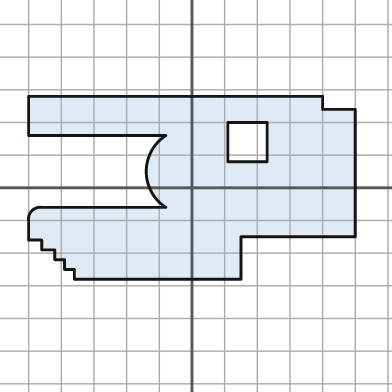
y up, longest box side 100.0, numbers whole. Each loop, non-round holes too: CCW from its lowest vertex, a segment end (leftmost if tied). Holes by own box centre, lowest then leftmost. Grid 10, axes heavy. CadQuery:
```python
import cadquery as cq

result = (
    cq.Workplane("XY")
    .moveTo(-36.0, -28.0)
    .lineTo(15.0, -28.0)
    .lineTo(15.0, -15.0)
    .lineTo(50.0, -15.0)
    .lineTo(50.0, 24.0)
    .lineTo(40.0, 24.0)
    .lineTo(40.0, 28.0)
    .lineTo(-50.0, 28.0)
    .lineTo(-50.0, 16.0)
    .lineTo(-8.0, 16.0)
    .threePointArc((-14.0, 5.0), (-8.0, -6.0))
    .lineTo(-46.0, -6.0)
    .threePointArc((-49.0, -7.0), (-50.0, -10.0))
    .lineTo(-50.0, -16.0)
    .lineTo(-46.0, -16.0)
    .lineTo(-46.0, -19.0)
    .lineTo(-42.0, -19.0)
    .lineTo(-42.0, -22.0)
    .lineTo(-39.0, -22.0)
    .lineTo(-39.0, -25.0)
    .lineTo(-36.0, -25.0)
    .close()
    .moveTo(11.0, 8.0)
    .lineTo(23.0, 8.0)
    .lineTo(23.0, 20.0)
    .lineTo(11.0, 20.0)
    .close()
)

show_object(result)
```